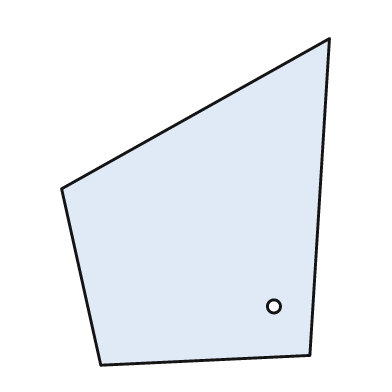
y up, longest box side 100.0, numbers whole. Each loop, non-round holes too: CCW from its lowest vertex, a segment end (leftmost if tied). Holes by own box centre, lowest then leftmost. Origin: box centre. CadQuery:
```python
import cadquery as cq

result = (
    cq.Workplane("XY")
    .moveTo(-29.0, -50.0)
    .lineTo(35.0, -47.0)
    .lineTo(41.0, 50.0)
    .lineTo(-41.0, 4.0)
    .close()
    .moveTo(24.0, -32.0)
    .circle(2.0)
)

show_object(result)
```